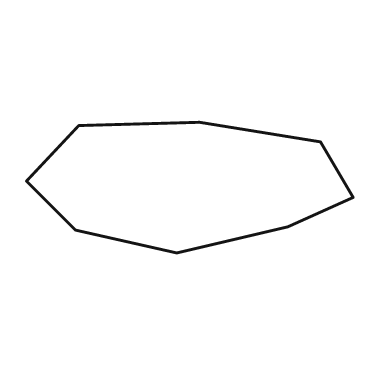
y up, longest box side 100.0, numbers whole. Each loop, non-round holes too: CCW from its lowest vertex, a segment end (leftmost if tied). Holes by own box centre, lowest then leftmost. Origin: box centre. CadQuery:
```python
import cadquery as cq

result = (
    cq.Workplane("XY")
    .moveTo(-4.0, -20.0)
    .lineTo(30.0, -12.0)
    .lineTo(50.0, -3.0)
    .lineTo(40.0, 14.0)
    .lineTo(3.0, 20.0)
    .lineTo(-34.0, 19.0)
    .lineTo(-50.0, 2.0)
    .lineTo(-35.0, -13.0)
    .close()
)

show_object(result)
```